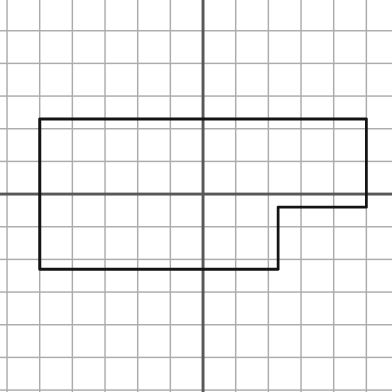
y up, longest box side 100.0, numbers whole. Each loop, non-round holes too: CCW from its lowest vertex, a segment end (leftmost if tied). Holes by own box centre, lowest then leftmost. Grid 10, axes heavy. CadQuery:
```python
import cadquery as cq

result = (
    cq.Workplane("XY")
    .moveTo(-50.0, -23.0)
    .lineTo(23.0, -23.0)
    .lineTo(23.0, -4.0)
    .lineTo(50.0, -4.0)
    .lineTo(50.0, 23.0)
    .lineTo(-50.0, 23.0)
    .close()
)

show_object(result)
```